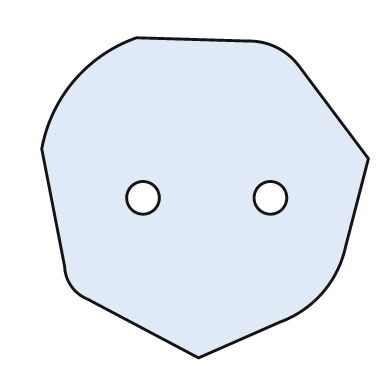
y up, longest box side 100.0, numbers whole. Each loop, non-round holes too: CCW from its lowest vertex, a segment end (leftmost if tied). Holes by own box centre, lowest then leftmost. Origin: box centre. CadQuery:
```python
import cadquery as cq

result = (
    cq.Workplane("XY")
    .moveTo(-2.0, -49.0)
    .lineTo(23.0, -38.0)
    .threePointArc((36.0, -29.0), (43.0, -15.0))
    .lineTo(50.0, 12.0)
    .lineTo(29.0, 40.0)
    .threePointArc((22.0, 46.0), (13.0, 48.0))
    .lineTo(-21.0, 49.0)
    .threePointArc((-40.0, 36.0), (-50.0, 15.0))
    .lineTo(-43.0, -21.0)
    .threePointArc((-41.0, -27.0), (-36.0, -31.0))
    .close()
    .moveTo(-19.0, 0.0)
    .circle(5.0)
    .moveTo(20.0, 0.0)
    .circle(5.0)
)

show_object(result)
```